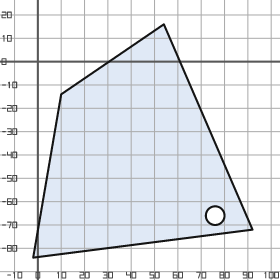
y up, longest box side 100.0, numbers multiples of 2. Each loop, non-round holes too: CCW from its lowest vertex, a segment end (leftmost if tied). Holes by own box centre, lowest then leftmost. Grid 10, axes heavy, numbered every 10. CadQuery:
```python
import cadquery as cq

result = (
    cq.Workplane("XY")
    .moveTo(-2.0, -84.0)
    .lineTo(92.0, -72.0)
    .lineTo(54.0, 16.0)
    .lineTo(10.0, -14.0)
    .close()
    .moveTo(76.0, -66.0)
    .circle(4.0)
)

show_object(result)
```